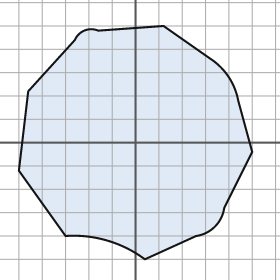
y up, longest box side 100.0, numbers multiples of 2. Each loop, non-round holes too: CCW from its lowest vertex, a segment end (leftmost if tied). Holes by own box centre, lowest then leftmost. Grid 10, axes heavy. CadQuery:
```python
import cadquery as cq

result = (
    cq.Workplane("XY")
    .moveTo(4.0, -50.0)
    .lineTo(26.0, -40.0)
    .threePointArc((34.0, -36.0), (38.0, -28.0))
    .lineTo(50.0, -4.0)
    .lineTo(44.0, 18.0)
    .threePointArc((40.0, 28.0), (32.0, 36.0))
    .lineTo(12.0, 50.0)
    .lineTo(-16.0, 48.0)
    .threePointArc((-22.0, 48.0), (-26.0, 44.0))
    .lineTo(-46.0, 22.0)
    .lineTo(-50.0, -12.0)
    .lineTo(-30.0, -40.0)
    .threePointArc((-12.0, -42.0), (4.0, -50.0))
    .close()
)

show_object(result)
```